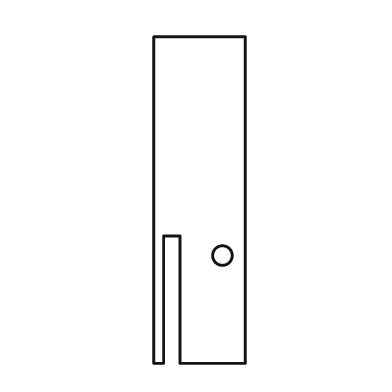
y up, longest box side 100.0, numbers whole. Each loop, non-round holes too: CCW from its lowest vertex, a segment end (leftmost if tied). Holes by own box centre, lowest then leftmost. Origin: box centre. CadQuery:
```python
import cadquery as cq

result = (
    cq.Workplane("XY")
    .moveTo(-14.0, -50.0)
    .lineTo(-11.0, -50.0)
    .lineTo(-11.0, -11.0)
    .lineTo(-6.0, -11.0)
    .lineTo(-6.0, -50.0)
    .lineTo(14.0, -50.0)
    .lineTo(14.0, 50.0)
    .lineTo(-14.0, 50.0)
    .close()
    .moveTo(7.0, -17.0)
    .circle(3.0)
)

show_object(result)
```